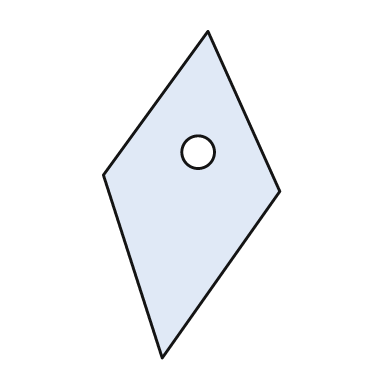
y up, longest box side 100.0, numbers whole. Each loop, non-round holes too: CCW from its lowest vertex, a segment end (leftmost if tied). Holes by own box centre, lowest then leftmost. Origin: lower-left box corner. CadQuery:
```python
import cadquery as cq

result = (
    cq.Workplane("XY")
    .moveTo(18.0, 0.0)
    .lineTo(54.0, 51.0)
    .lineTo(32.0, 100.0)
    .lineTo(0.0, 56.0)
    .close()
    .moveTo(29.0, 63.0)
    .circle(5.0)
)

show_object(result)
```